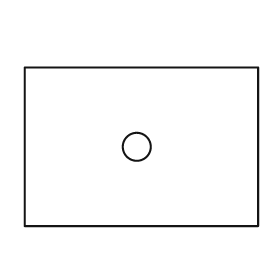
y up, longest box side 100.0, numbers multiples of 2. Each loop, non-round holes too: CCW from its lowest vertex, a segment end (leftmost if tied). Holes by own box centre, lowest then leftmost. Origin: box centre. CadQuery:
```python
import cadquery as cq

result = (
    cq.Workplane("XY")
    .moveTo(-50.0, -34.0)
    .lineTo(50.0, -34.0)
    .lineTo(50.0, 34.0)
    .lineTo(-50.0, 34.0)
    .close()
    .moveTo(-2.0, 0.0)
    .circle(6.0)
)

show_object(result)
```